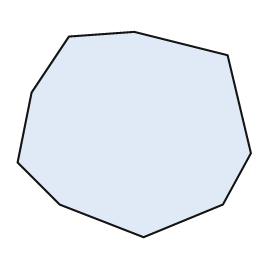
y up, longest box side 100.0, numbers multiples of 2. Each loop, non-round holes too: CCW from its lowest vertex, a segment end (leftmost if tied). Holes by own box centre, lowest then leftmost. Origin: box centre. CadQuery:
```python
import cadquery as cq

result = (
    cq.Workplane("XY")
    .moveTo(4.0, -44.0)
    .lineTo(38.0, -30.0)
    .lineTo(50.0, -8.0)
    .lineTo(40.0, 34.0)
    .lineTo(0.0, 44.0)
    .lineTo(-28.0, 42.0)
    .lineTo(-44.0, 18.0)
    .lineTo(-50.0, -12.0)
    .lineTo(-32.0, -30.0)
    .close()
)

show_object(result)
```